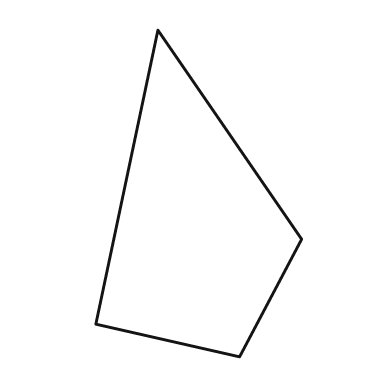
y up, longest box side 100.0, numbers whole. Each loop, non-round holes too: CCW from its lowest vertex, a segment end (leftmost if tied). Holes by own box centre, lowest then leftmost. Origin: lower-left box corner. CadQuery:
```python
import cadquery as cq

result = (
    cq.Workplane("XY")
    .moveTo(44.0, 0.0)
    .lineTo(63.0, 36.0)
    .lineTo(19.0, 100.0)
    .lineTo(0.0, 10.0)
    .close()
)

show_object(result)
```